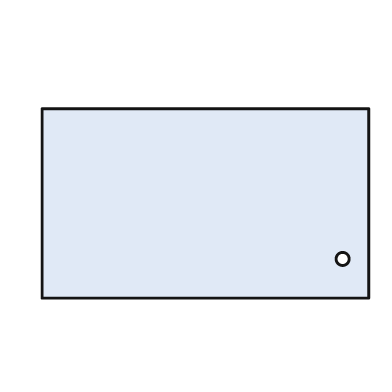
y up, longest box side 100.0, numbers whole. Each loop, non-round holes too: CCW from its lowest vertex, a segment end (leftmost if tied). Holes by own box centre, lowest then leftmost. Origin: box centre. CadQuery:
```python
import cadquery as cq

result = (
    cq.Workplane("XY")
    .moveTo(-50.0, -29.0)
    .lineTo(50.0, -29.0)
    .lineTo(50.0, 29.0)
    .lineTo(-50.0, 29.0)
    .close()
    .moveTo(42.0, -17.0)
    .circle(2.0)
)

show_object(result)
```